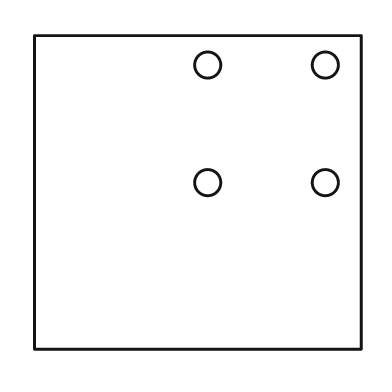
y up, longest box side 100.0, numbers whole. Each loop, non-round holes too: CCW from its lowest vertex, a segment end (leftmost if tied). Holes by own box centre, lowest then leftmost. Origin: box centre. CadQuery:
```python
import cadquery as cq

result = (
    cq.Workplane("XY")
    .moveTo(-50.0, -48.0)
    .lineTo(50.0, -48.0)
    .lineTo(50.0, 48.0)
    .lineTo(-50.0, 48.0)
    .close()
    .moveTo(3.0, 3.0)
    .circle(4.0)
    .moveTo(39.0, 3.0)
    .circle(4.0)
    .moveTo(3.0, 39.0)
    .circle(4.0)
    .moveTo(39.0, 39.0)
    .circle(4.0)
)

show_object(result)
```